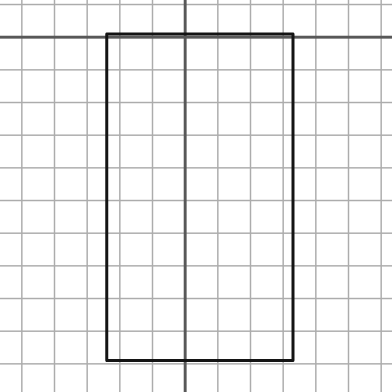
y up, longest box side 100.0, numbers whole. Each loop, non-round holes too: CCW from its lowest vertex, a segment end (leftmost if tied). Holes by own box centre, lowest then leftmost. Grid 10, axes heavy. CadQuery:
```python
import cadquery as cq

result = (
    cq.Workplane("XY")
    .moveTo(-24.0, -99.0)
    .lineTo(33.0, -99.0)
    .lineTo(33.0, 1.0)
    .lineTo(-24.0, 1.0)
    .close()
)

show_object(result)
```